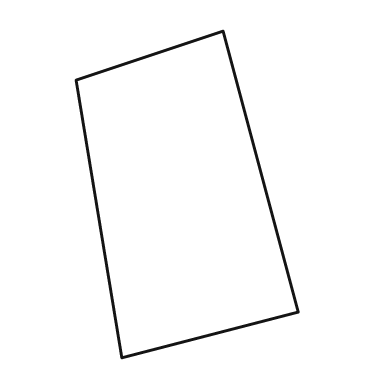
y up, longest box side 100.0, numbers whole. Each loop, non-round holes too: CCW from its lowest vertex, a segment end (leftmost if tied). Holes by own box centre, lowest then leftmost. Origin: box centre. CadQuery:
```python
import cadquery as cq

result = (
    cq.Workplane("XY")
    .moveTo(-20.0, -50.0)
    .lineTo(34.0, -36.0)
    .lineTo(11.0, 50.0)
    .lineTo(-34.0, 35.0)
    .close()
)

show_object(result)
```